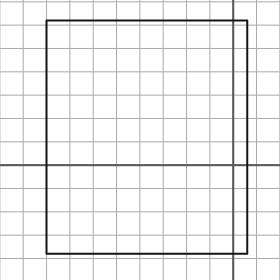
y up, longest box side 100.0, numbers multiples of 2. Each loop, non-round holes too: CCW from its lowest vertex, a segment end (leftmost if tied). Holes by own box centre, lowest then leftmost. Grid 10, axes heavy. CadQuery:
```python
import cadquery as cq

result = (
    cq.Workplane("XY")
    .moveTo(-80.0, -38.0)
    .lineTo(6.0, -38.0)
    .lineTo(6.0, 62.0)
    .lineTo(-80.0, 62.0)
    .close()
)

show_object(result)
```